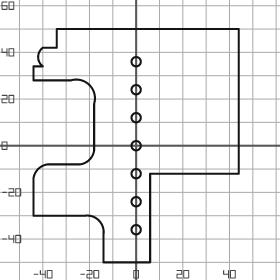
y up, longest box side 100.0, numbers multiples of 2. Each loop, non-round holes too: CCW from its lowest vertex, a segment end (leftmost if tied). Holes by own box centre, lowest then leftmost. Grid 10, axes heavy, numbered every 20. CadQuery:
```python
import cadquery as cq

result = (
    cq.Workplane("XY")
    .moveTo(-14.0, -50.0)
    .lineTo(6.0, -50.0)
    .lineTo(6.0, -12.0)
    .lineTo(44.0, -12.0)
    .lineTo(44.0, 50.0)
    .lineTo(-34.0, 50.0)
    .lineTo(-34.0, 42.0)
    .lineTo(-40.0, 42.0)
    .threePointArc((-42.0, 38.0), (-40.0, 34.0))
    .lineTo(-44.0, 34.0)
    .lineTo(-44.0, 28.0)
    .lineTo(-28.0, 28.0)
    .threePointArc((-20.0, 26.0), (-18.0, 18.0))
    .lineTo(-18.0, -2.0)
    .threePointArc((-20.0, -6.0), (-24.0, -8.0))
    .lineTo(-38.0, -8.0)
    .threePointArc((-42.0, -10.0), (-44.0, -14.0))
    .lineTo(-44.0, -30.0)
    .lineTo(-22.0, -30.0)
    .threePointArc((-16.0, -32.0), (-14.0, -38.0))
    .close()
    .moveTo(0.0, -36.0)
    .circle(2.0)
    .moveTo(0.0, -24.0)
    .circle(2.0)
    .moveTo(0.0, -12.0)
    .circle(2.0)
    .moveTo(0.0, 0.0)
    .circle(2.0)
    .moveTo(0.0, 12.0)
    .circle(2.0)
    .moveTo(0.0, 24.0)
    .circle(2.0)
    .moveTo(0.0, 36.0)
    .circle(2.0)
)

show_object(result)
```